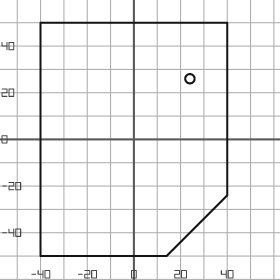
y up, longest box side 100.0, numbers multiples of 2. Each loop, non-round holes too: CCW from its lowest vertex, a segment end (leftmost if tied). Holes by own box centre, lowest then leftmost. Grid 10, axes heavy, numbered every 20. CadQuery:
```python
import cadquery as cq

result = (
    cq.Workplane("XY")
    .moveTo(-40.0, -50.0)
    .lineTo(14.0, -50.0)
    .lineTo(40.0, -24.0)
    .lineTo(40.0, 50.0)
    .lineTo(-40.0, 50.0)
    .close()
    .moveTo(24.0, 26.0)
    .circle(2.0)
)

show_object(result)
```